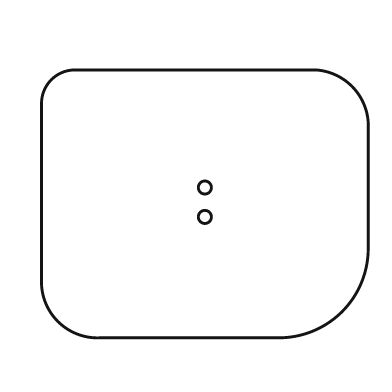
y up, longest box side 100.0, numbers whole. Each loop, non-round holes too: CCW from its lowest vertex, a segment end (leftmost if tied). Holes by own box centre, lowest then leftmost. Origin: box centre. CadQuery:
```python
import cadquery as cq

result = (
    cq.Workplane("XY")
    .moveTo(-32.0, -41.0)
    .lineTo(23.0, -41.0)
    .threePointArc((42.0, -33.0), (50.0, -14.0))
    .lineTo(50.0, 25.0)
    .threePointArc((45.0, 36.0), (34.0, 41.0))
    .lineTo(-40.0, 41.0)
    .threePointArc((-47.0, 38.0), (-50.0, 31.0))
    .lineTo(-50.0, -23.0)
    .threePointArc((-45.0, -36.0), (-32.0, -41.0))
    .close()
    .moveTo(0.0, -4.0)
    .circle(2.0)
    .moveTo(0.0, 5.0)
    .circle(2.0)
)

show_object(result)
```